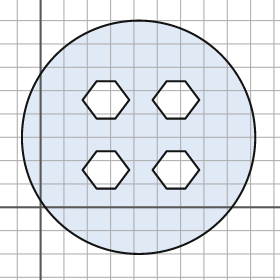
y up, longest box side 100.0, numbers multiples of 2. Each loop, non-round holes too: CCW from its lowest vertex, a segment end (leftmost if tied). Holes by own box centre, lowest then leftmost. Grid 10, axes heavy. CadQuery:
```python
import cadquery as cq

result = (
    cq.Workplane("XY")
    .moveTo(42.0, 30.0)
    .circle(50.0)
    .moveTo(24.0, 8.0)
    .lineTo(32.0, 8.0)
    .lineTo(38.0, 16.0)
    .lineTo(32.0, 24.0)
    .lineTo(24.0, 24.0)
    .lineTo(18.0, 16.0)
    .close()
    .moveTo(54.0, 8.0)
    .lineTo(62.0, 8.0)
    .lineTo(68.0, 16.0)
    .lineTo(62.0, 24.0)
    .lineTo(54.0, 24.0)
    .lineTo(48.0, 16.0)
    .close()
    .moveTo(24.0, 38.0)
    .lineTo(32.0, 38.0)
    .lineTo(38.0, 46.0)
    .lineTo(32.0, 54.0)
    .lineTo(24.0, 54.0)
    .lineTo(18.0, 46.0)
    .close()
    .moveTo(54.0, 38.0)
    .lineTo(62.0, 38.0)
    .lineTo(68.0, 46.0)
    .lineTo(62.0, 54.0)
    .lineTo(54.0, 54.0)
    .lineTo(48.0, 46.0)
    .close()
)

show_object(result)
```